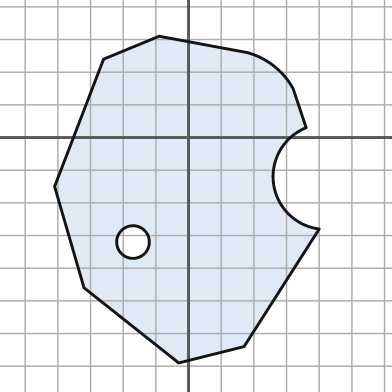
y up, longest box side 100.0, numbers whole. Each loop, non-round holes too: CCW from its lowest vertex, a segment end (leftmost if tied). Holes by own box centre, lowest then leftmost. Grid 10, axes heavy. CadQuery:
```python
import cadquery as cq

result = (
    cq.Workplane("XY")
    .moveTo(-3.0, -69.0)
    .lineTo(17.0, -64.0)
    .lineTo(40.0, -28.0)
    .threePointArc((26.0, -14.0), (36.0, 3.0))
    .lineTo(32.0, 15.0)
    .threePointArc((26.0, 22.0), (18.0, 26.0))
    .lineTo(-9.0, 31.0)
    .lineTo(-26.0, 24.0)
    .lineTo(-41.0, -15.0)
    .lineTo(-32.0, -46.0)
    .close()
    .moveTo(-17.0, -32.0)
    .circle(5.0)
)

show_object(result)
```